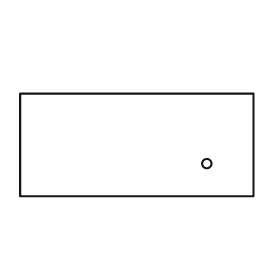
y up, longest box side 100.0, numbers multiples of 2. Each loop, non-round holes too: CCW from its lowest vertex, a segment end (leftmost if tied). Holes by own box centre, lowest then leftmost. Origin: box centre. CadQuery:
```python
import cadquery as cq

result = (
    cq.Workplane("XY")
    .moveTo(-50.0, -22.0)
    .lineTo(50.0, -22.0)
    .lineTo(50.0, 22.0)
    .lineTo(-50.0, 22.0)
    .close()
    .moveTo(30.0, -8.0)
    .circle(2.0)
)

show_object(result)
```